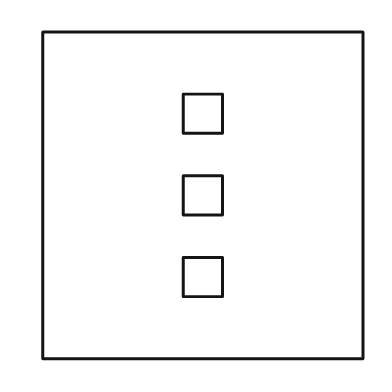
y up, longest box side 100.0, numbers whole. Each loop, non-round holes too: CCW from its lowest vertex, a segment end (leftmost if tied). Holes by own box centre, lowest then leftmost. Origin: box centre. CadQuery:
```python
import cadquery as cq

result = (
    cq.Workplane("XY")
    .moveTo(-49.0, -50.0)
    .lineTo(49.0, -50.0)
    .lineTo(49.0, 50.0)
    .lineTo(-49.0, 50.0)
    .close()
    .moveTo(-6.0, -31.0)
    .lineTo(6.0, -31.0)
    .lineTo(6.0, -19.0)
    .lineTo(-6.0, -19.0)
    .close()
    .moveTo(-6.0, -6.0)
    .lineTo(6.0, -6.0)
    .lineTo(6.0, 6.0)
    .lineTo(-6.0, 6.0)
    .close()
    .moveTo(-6.0, 19.0)
    .lineTo(6.0, 19.0)
    .lineTo(6.0, 31.0)
    .lineTo(-6.0, 31.0)
    .close()
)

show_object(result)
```